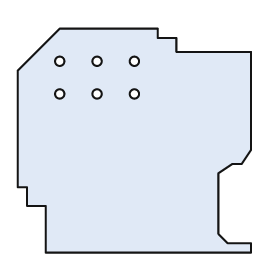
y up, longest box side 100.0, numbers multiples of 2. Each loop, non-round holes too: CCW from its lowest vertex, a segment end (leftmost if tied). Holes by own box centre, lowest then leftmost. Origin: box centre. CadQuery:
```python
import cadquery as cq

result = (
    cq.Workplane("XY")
    .moveTo(-38.0, -48.0)
    .lineTo(50.0, -48.0)
    .lineTo(50.0, -44.0)
    .lineTo(40.0, -44.0)
    .lineTo(36.0, -40.0)
    .lineTo(36.0, -14.0)
    .lineTo(42.0, -10.0)
    .lineTo(46.0, -10.0)
    .lineTo(50.0, -4.0)
    .lineTo(50.0, 38.0)
    .lineTo(18.0, 38.0)
    .lineTo(18.0, 44.0)
    .lineTo(10.0, 44.0)
    .lineTo(10.0, 48.0)
    .lineTo(-32.0, 48.0)
    .lineTo(-50.0, 30.0)
    .lineTo(-50.0, -20.0)
    .lineTo(-46.0, -20.0)
    .lineTo(-46.0, -28.0)
    .lineTo(-38.0, -28.0)
    .close()
    .moveTo(-32.0, 20.0)
    .circle(2.0)
    .moveTo(-16.0, 20.0)
    .circle(2.0)
    .moveTo(0.0, 20.0)
    .circle(2.0)
    .moveTo(-32.0, 34.0)
    .circle(2.0)
    .moveTo(-16.0, 34.0)
    .circle(2.0)
    .moveTo(0.0, 34.0)
    .circle(2.0)
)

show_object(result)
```